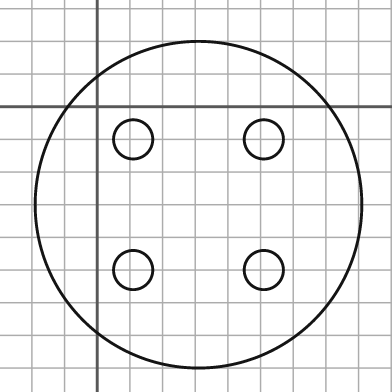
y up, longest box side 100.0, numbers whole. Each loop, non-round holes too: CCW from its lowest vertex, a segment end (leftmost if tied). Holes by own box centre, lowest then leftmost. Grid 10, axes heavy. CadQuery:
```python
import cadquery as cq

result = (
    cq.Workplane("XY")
    .moveTo(31.0, -30.0)
    .circle(50.0)
    .moveTo(11.0, -50.0)
    .circle(6.0)
    .moveTo(51.0, -50.0)
    .circle(6.0)
    .moveTo(11.0, -10.0)
    .circle(6.0)
    .moveTo(51.0, -10.0)
    .circle(6.0)
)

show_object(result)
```